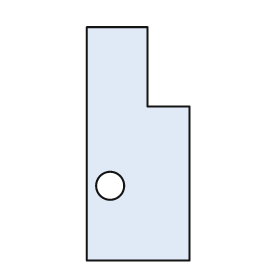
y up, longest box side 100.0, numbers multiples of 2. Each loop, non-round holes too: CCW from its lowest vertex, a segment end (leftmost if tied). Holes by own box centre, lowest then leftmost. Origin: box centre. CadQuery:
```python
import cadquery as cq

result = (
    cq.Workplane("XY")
    .moveTo(-22.0, -50.0)
    .lineTo(22.0, -50.0)
    .lineTo(22.0, 16.0)
    .lineTo(4.0, 16.0)
    .lineTo(4.0, 50.0)
    .lineTo(-22.0, 50.0)
    .close()
    .moveTo(-12.0, -18.0)
    .circle(6.0)
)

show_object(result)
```